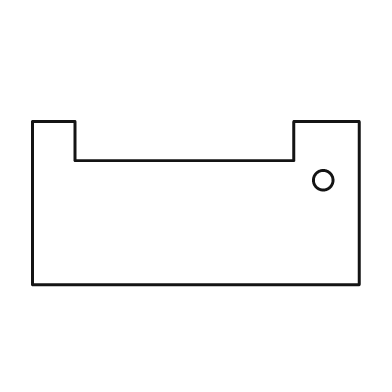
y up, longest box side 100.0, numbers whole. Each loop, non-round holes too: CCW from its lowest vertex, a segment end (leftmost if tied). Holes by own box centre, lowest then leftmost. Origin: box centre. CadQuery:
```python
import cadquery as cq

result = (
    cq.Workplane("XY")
    .moveTo(-50.0, -25.0)
    .lineTo(50.0, -25.0)
    .lineTo(50.0, 25.0)
    .lineTo(30.0, 25.0)
    .lineTo(30.0, 13.0)
    .lineTo(-37.0, 13.0)
    .lineTo(-37.0, 25.0)
    .lineTo(-50.0, 25.0)
    .close()
    .moveTo(39.0, 7.0)
    .circle(3.0)
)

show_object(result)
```